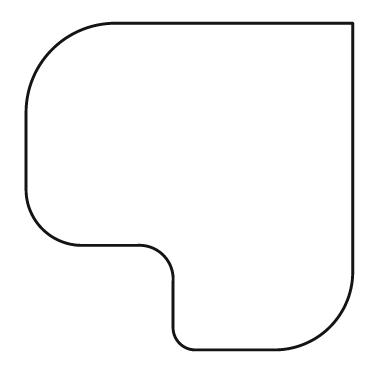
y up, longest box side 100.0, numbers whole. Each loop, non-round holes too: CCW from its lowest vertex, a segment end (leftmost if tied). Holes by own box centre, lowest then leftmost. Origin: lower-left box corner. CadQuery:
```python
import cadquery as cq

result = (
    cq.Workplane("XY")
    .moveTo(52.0, 0.0)
    .lineTo(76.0, 0.0)
    .threePointArc((93.0, 7.0), (100.0, 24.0))
    .lineTo(100.0, 100.0)
    .lineTo(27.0, 100.0)
    .threePointArc((8.0, 92.0), (0.0, 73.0))
    .lineTo(0.0, 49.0)
    .threePointArc((5.0, 37.0), (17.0, 32.0))
    .lineTo(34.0, 32.0)
    .threePointArc((42.0, 29.0), (45.0, 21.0))
    .lineTo(45.0, 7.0)
    .threePointArc((47.0, 2.0), (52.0, 0.0))
    .close()
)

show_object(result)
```